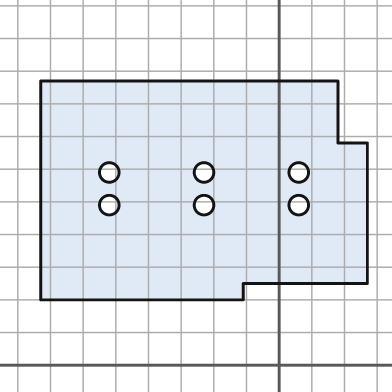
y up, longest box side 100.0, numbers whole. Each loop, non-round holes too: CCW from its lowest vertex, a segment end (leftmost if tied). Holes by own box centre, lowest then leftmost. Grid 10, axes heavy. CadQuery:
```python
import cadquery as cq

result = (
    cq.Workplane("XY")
    .moveTo(-73.0, 20.0)
    .lineTo(-11.0, 20.0)
    .lineTo(-11.0, 25.0)
    .lineTo(27.0, 25.0)
    .lineTo(27.0, 68.0)
    .lineTo(18.0, 68.0)
    .lineTo(18.0, 87.0)
    .lineTo(-73.0, 87.0)
    .close()
    .moveTo(-52.0, 49.0)
    .circle(3.0)
    .moveTo(-23.0, 49.0)
    .circle(3.0)
    .moveTo(6.0, 49.0)
    .circle(3.0)
    .moveTo(-52.0, 59.0)
    .circle(3.0)
    .moveTo(-23.0, 59.0)
    .circle(3.0)
    .moveTo(6.0, 59.0)
    .circle(3.0)
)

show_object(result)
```